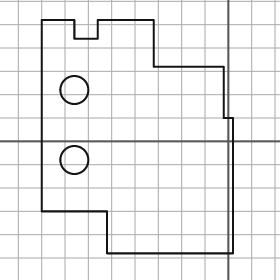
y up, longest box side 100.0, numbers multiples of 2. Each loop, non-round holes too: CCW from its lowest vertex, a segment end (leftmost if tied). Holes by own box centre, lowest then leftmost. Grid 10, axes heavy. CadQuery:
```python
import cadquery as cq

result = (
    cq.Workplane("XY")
    .moveTo(-52.0, -48.0)
    .lineTo(2.0, -48.0)
    .lineTo(2.0, 10.0)
    .lineTo(-2.0, 10.0)
    .lineTo(-2.0, 32.0)
    .lineTo(-32.0, 32.0)
    .lineTo(-32.0, 52.0)
    .lineTo(-56.0, 52.0)
    .lineTo(-56.0, 44.0)
    .lineTo(-66.0, 44.0)
    .lineTo(-66.0, 52.0)
    .lineTo(-80.0, 52.0)
    .lineTo(-80.0, -30.0)
    .lineTo(-52.0, -30.0)
    .close()
    .moveTo(-66.0, -8.0)
    .circle(6.0)
    .moveTo(-66.0, 22.0)
    .circle(6.0)
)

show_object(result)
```